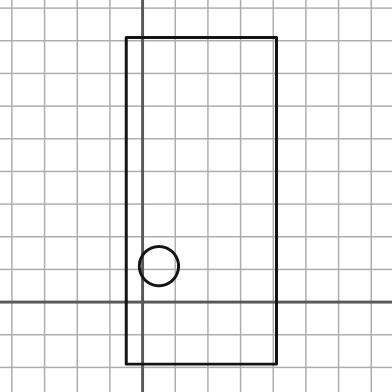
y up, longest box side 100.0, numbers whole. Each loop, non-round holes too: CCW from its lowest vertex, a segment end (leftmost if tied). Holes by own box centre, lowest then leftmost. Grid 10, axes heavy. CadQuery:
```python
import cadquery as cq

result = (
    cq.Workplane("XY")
    .moveTo(-5.0, -19.0)
    .lineTo(41.0, -19.0)
    .lineTo(41.0, 81.0)
    .lineTo(-5.0, 81.0)
    .close()
    .moveTo(5.0, 11.0)
    .circle(6.0)
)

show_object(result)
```